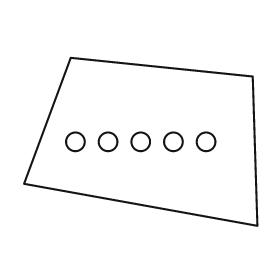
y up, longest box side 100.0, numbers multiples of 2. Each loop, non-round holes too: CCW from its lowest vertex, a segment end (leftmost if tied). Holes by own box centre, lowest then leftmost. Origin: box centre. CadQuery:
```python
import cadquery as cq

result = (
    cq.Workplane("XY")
    .moveTo(50.0, -36.0)
    .lineTo(48.0, 28.0)
    .lineTo(-30.0, 36.0)
    .lineTo(-50.0, -18.0)
    .close()
    .moveTo(-28.0, 0.0)
    .circle(4.0)
    .moveTo(-14.0, 0.0)
    .circle(4.0)
    .moveTo(0.0, 0.0)
    .circle(4.0)
    .moveTo(14.0, 0.0)
    .circle(4.0)
    .moveTo(28.0, 0.0)
    .circle(4.0)
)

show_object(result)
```